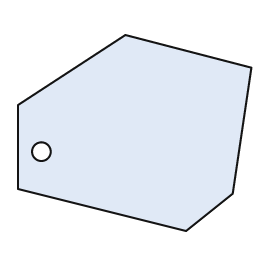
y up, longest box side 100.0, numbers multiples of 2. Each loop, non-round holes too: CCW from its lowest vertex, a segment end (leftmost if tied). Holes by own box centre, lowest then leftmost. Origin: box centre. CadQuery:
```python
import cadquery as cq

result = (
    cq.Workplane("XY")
    .moveTo(22.0, -42.0)
    .lineTo(42.0, -26.0)
    .lineTo(50.0, 28.0)
    .lineTo(-4.0, 42.0)
    .lineTo(-50.0, 12.0)
    .lineTo(-50.0, -24.0)
    .close()
    .moveTo(-40.0, -8.0)
    .circle(4.0)
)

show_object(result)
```